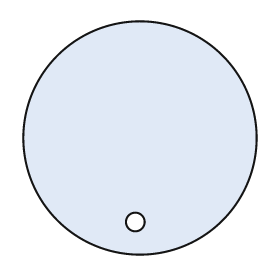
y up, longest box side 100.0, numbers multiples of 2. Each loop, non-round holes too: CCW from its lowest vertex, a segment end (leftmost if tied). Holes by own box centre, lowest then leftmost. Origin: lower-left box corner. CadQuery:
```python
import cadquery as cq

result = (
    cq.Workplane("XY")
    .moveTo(50.0, 50.0)
    .circle(50.0)
    .moveTo(48.0, 14.0)
    .circle(4.0)
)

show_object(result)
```